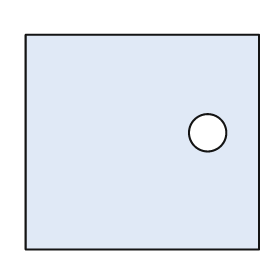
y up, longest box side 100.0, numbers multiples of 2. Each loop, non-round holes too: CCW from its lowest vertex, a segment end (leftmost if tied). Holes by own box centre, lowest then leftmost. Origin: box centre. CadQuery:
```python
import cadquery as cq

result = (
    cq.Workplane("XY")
    .moveTo(-50.0, -46.0)
    .lineTo(50.0, -46.0)
    .lineTo(50.0, 46.0)
    .lineTo(-50.0, 46.0)
    .close()
    .moveTo(28.0, 4.0)
    .circle(8.0)
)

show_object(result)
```